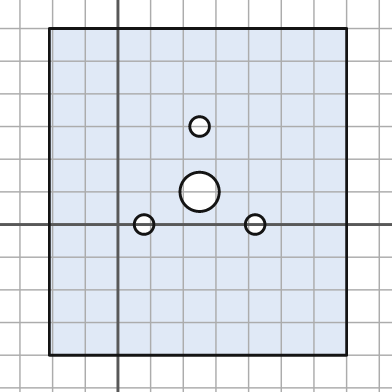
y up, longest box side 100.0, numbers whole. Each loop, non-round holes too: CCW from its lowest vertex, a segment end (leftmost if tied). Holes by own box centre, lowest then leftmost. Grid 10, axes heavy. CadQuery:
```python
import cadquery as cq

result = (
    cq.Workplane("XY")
    .moveTo(-21.0, -40.0)
    .lineTo(70.0, -40.0)
    .lineTo(70.0, 60.0)
    .lineTo(-21.0, 60.0)
    .close()
    .moveTo(8.0, 0.0)
    .circle(3.0)
    .moveTo(42.0, 0.0)
    .circle(3.0)
    .moveTo(25.0, 10.0)
    .circle(6.0)
    .moveTo(25.0, 30.0)
    .circle(3.0)
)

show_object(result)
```